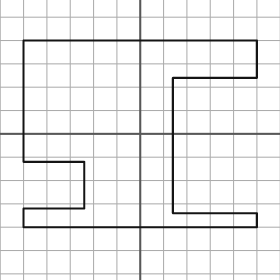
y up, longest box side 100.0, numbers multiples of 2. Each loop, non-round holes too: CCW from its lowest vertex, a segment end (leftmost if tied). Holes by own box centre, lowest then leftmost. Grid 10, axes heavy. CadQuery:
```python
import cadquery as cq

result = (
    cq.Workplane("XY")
    .moveTo(-50.0, -40.0)
    .lineTo(50.0, -40.0)
    .lineTo(50.0, -34.0)
    .lineTo(14.0, -34.0)
    .lineTo(14.0, 24.0)
    .lineTo(50.0, 24.0)
    .lineTo(50.0, 40.0)
    .lineTo(-50.0, 40.0)
    .lineTo(-50.0, -12.0)
    .lineTo(-24.0, -12.0)
    .lineTo(-24.0, -32.0)
    .lineTo(-50.0, -32.0)
    .close()
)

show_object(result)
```